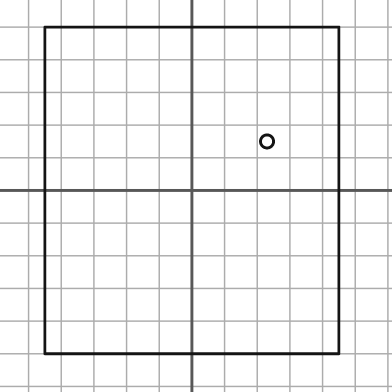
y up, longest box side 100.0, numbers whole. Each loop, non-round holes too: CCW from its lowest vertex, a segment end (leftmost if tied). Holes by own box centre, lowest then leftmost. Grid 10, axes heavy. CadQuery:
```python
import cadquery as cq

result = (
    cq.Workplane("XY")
    .moveTo(-45.0, -50.0)
    .lineTo(45.0, -50.0)
    .lineTo(45.0, 50.0)
    .lineTo(-45.0, 50.0)
    .close()
    .moveTo(23.0, 15.0)
    .circle(2.0)
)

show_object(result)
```